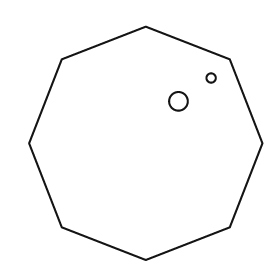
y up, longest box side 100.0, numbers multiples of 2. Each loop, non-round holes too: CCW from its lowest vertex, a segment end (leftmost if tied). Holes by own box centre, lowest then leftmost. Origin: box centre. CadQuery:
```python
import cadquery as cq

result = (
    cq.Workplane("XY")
    .moveTo(0.0, -50.0)
    .lineTo(36.0, -36.0)
    .lineTo(50.0, 0.0)
    .lineTo(36.0, 36.0)
    .lineTo(0.0, 50.0)
    .lineTo(-36.0, 36.0)
    .lineTo(-50.0, 0.0)
    .lineTo(-36.0, -36.0)
    .close()
    .moveTo(14.0, 18.0)
    .circle(4.0)
    .moveTo(28.0, 28.0)
    .circle(2.0)
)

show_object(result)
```